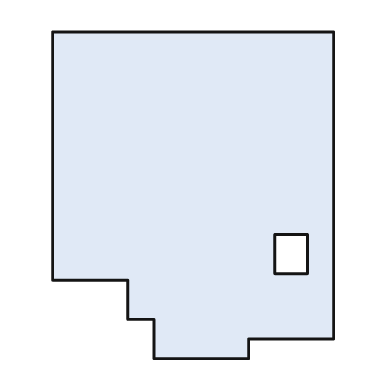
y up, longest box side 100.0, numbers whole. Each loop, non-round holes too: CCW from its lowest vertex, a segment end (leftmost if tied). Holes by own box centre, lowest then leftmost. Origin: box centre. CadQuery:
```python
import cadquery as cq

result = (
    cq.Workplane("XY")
    .moveTo(-12.0, -50.0)
    .lineTo(17.0, -50.0)
    .lineTo(17.0, -44.0)
    .lineTo(43.0, -44.0)
    .lineTo(43.0, 50.0)
    .lineTo(-43.0, 50.0)
    .lineTo(-43.0, -26.0)
    .lineTo(-20.0, -26.0)
    .lineTo(-20.0, -38.0)
    .lineTo(-12.0, -38.0)
    .close()
    .moveTo(25.0, -24.0)
    .lineTo(35.0, -24.0)
    .lineTo(35.0, -12.0)
    .lineTo(25.0, -12.0)
    .close()
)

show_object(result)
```